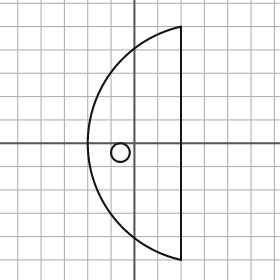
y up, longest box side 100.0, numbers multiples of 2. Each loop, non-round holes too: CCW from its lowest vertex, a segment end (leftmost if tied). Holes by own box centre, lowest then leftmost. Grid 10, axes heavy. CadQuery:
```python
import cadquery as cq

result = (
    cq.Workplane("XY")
    .moveTo(20.0, -50.0)
    .lineTo(20.0, 50.0)
    .threePointArc((-20.0, 0.0), (20.0, -50.0))
    .close()
    .moveTo(-6.0, -4.0)
    .circle(4.0)
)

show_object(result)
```